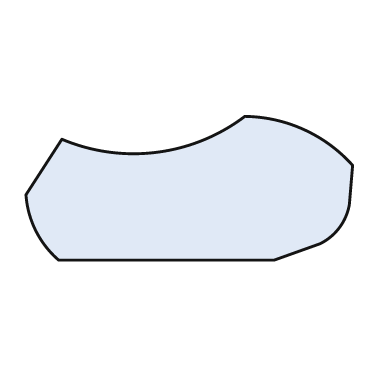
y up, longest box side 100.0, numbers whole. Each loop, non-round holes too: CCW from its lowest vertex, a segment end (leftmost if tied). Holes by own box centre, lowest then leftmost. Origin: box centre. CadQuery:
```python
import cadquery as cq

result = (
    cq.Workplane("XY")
    .moveTo(-40.0, -22.0)
    .lineTo(26.0, -22.0)
    .lineTo(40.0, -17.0)
    .threePointArc((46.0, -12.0), (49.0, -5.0))
    .lineTo(50.0, 7.0)
    .threePointArc((35.0, 18.0), (17.0, 22.0))
    .threePointArc((-10.0, 11.0), (-39.0, 15.0))
    .lineTo(-50.0, -2.0)
    .threePointArc((-47.0, -13.0), (-40.0, -22.0))
    .close()
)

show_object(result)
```